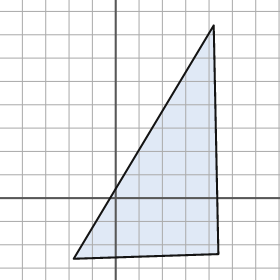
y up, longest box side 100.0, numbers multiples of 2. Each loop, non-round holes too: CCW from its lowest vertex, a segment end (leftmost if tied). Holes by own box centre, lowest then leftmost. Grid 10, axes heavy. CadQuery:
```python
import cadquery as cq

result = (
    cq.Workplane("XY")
    .moveTo(-18.0, -26.0)
    .lineTo(44.0, -24.0)
    .lineTo(42.0, 74.0)
    .close()
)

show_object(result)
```